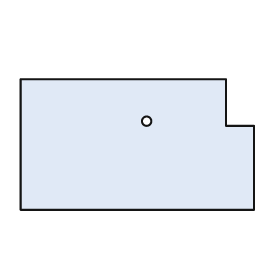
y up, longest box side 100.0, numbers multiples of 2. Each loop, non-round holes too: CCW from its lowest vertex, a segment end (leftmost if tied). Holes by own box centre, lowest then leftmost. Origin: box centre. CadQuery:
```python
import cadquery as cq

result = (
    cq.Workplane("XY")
    .moveTo(-50.0, -28.0)
    .lineTo(50.0, -28.0)
    .lineTo(50.0, 8.0)
    .lineTo(38.0, 8.0)
    .lineTo(38.0, 28.0)
    .lineTo(-50.0, 28.0)
    .close()
    .moveTo(4.0, 10.0)
    .circle(2.0)
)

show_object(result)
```